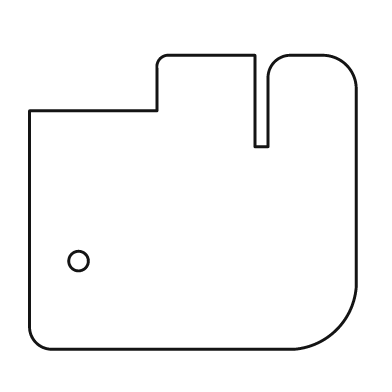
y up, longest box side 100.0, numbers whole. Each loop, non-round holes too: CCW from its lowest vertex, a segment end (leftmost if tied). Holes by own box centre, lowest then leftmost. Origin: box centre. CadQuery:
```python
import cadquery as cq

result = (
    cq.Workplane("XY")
    .moveTo(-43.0, -45.0)
    .lineTo(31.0, -45.0)
    .threePointArc((44.0, -39.0), (50.0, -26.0))
    .lineTo(50.0, 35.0)
    .threePointArc((47.0, 42.0), (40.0, 45.0))
    .lineTo(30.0, 45.0)
    .threePointArc((25.0, 43.0), (23.0, 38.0))
    .lineTo(23.0, 17.0)
    .lineTo(19.0, 17.0)
    .lineTo(19.0, 45.0)
    .lineTo(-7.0, 45.0)
    .threePointArc((-10.0, 44.0), (-11.0, 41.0))
    .lineTo(-11.0, 28.0)
    .lineTo(-50.0, 28.0)
    .lineTo(-50.0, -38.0)
    .threePointArc((-48.0, -43.0), (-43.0, -45.0))
    .close()
    .moveTo(-35.0, -18.0)
    .circle(3.0)
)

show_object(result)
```